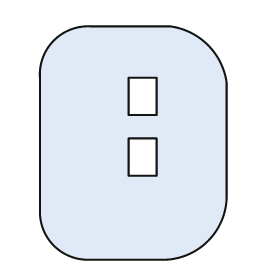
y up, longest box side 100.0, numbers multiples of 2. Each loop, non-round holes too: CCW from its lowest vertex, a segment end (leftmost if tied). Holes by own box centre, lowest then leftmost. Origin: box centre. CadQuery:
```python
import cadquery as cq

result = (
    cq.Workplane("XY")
    .moveTo(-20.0, -50.0)
    .lineTo(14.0, -50.0)
    .threePointArc((32.0, -42.0), (40.0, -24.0))
    .lineTo(40.0, 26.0)
    .threePointArc((32.0, 42.0), (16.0, 50.0))
    .lineTo(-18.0, 50.0)
    .threePointArc((-34.0, 44.0), (-40.0, 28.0))
    .lineTo(-40.0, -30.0)
    .threePointArc((-34.0, -44.0), (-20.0, -50.0))
    .close()
    .moveTo(-2.0, -14.0)
    .lineTo(10.0, -14.0)
    .lineTo(10.0, 2.0)
    .lineTo(-2.0, 2.0)
    .close()
    .moveTo(-2.0, 12.0)
    .lineTo(10.0, 12.0)
    .lineTo(10.0, 28.0)
    .lineTo(-2.0, 28.0)
    .close()
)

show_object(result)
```